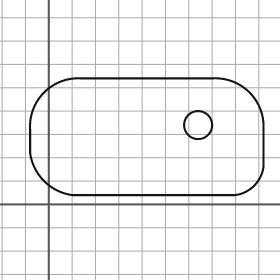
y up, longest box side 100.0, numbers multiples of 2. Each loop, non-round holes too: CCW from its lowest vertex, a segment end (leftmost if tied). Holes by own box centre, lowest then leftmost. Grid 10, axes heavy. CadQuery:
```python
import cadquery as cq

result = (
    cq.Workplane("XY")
    .moveTo(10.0, 4.0)
    .lineTo(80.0, 4.0)
    .threePointArc((88.0, 8.0), (92.0, 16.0))
    .lineTo(92.0, 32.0)
    .threePointArc((86.0, 48.0), (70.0, 54.0))
    .lineTo(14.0, 54.0)
    .threePointArc((-2.0, 48.0), (-8.0, 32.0))
    .lineTo(-8.0, 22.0)
    .threePointArc((-2.0, 10.0), (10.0, 4.0))
    .close()
    .moveTo(64.0, 34.0)
    .circle(6.0)
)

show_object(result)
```